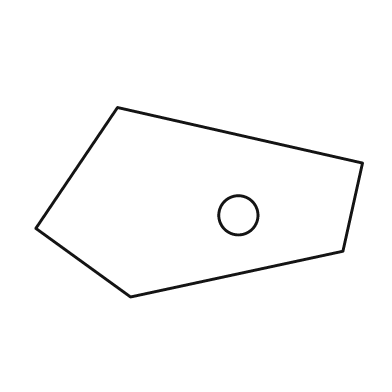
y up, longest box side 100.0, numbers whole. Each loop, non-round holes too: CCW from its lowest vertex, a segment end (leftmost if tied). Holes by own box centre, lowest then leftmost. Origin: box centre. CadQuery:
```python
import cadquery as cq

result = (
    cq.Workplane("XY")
    .moveTo(-21.0, -29.0)
    .lineTo(44.0, -15.0)
    .lineTo(50.0, 12.0)
    .lineTo(-25.0, 29.0)
    .lineTo(-50.0, -8.0)
    .close()
    .moveTo(12.0, -4.0)
    .circle(6.0)
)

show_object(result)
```